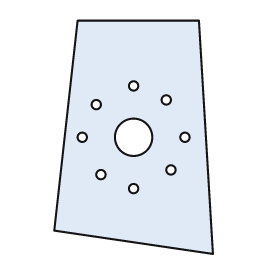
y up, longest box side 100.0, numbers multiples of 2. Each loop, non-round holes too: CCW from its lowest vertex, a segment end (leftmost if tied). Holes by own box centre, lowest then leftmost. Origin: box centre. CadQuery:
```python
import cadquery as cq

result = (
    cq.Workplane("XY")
    .moveTo(34.0, -50.0)
    .lineTo(28.0, 50.0)
    .lineTo(-24.0, 50.0)
    .lineTo(-34.0, -40.0)
    .close()
    .moveTo(0.0, -22.0)
    .circle(2.0)
    .moveTo(-14.0, -16.0)
    .circle(2.0)
    .moveTo(16.0, -14.0)
    .circle(2.0)
    .moveTo(-22.0, 0.0)
    .circle(2.0)
    .moveTo(0.0, 0.0)
    .circle(8.0)
    .moveTo(22.0, 0.0)
    .circle(2.0)
    .moveTo(-16.0, 14.0)
    .circle(2.0)
    .moveTo(14.0, 16.0)
    .circle(2.0)
    .moveTo(0.0, 22.0)
    .circle(2.0)
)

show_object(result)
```